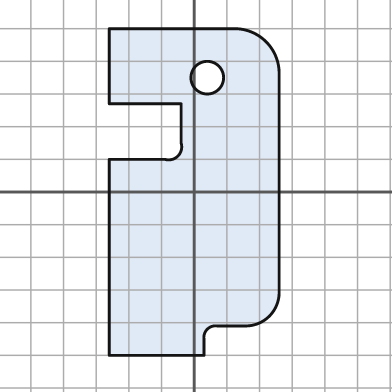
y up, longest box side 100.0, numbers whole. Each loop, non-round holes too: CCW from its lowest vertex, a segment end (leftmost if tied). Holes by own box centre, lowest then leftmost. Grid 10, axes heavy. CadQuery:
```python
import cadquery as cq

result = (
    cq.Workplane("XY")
    .moveTo(-26.0, -50.0)
    .lineTo(3.0, -50.0)
    .lineTo(3.0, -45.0)
    .threePointArc((4.0, -42.0), (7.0, -41.0))
    .lineTo(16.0, -41.0)
    .threePointArc((23.0, -38.0), (26.0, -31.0))
    .lineTo(26.0, 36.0)
    .threePointArc((22.0, 46.0), (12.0, 50.0))
    .lineTo(-26.0, 50.0)
    .lineTo(-26.0, 27.0)
    .lineTo(-4.0, 27.0)
    .lineTo(-4.0, 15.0)
    .threePointArc((-5.0, 11.0), (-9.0, 10.0))
    .lineTo(-26.0, 10.0)
    .close()
    .moveTo(4.0, 35.0)
    .circle(5.0)
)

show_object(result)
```